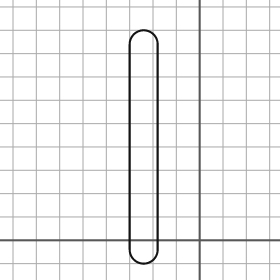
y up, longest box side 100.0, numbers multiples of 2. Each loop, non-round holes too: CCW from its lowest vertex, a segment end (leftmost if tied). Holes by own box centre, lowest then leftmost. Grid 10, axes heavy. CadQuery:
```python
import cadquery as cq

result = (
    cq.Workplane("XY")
    .moveTo(-30.0, -4.0)
    .threePointArc((-24.0, -10.0), (-18.0, -4.0))
    .lineTo(-18.0, 84.0)
    .threePointArc((-24.0, 90.0), (-30.0, 84.0))
    .close()
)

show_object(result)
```